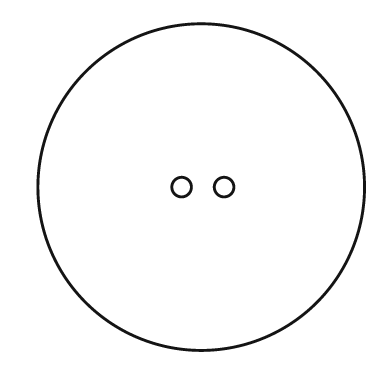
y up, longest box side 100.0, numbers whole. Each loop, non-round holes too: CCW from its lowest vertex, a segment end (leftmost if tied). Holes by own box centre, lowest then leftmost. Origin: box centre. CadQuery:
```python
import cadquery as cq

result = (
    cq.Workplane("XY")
    .moveTo(0.0, 0.0)
    .circle(50.0)
    .moveTo(-6.0, 0.0)
    .circle(3.0)
    .moveTo(7.0, 0.0)
    .circle(3.0)
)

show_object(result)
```